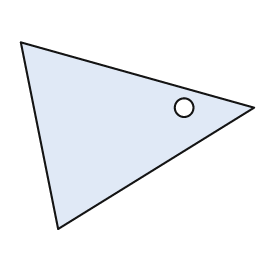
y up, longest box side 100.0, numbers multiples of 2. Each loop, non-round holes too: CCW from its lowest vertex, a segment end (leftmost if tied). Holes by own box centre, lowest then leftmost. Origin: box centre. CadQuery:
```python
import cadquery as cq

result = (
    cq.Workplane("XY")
    .moveTo(-34.0, -40.0)
    .lineTo(50.0, 12.0)
    .lineTo(-50.0, 40.0)
    .close()
    .moveTo(20.0, 12.0)
    .circle(4.0)
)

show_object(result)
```